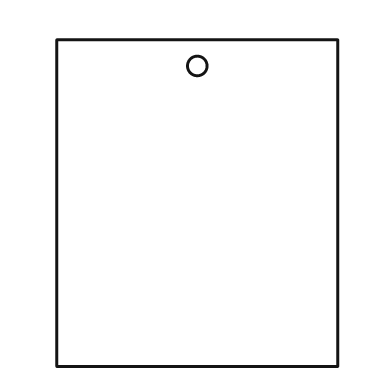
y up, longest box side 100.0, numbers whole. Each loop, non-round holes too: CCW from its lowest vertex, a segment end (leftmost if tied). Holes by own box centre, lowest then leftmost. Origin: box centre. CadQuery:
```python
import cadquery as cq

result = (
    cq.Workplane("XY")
    .moveTo(-43.0, -50.0)
    .lineTo(43.0, -50.0)
    .lineTo(43.0, 50.0)
    .lineTo(-43.0, 50.0)
    .close()
    .moveTo(0.0, 42.0)
    .circle(3.0)
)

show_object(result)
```